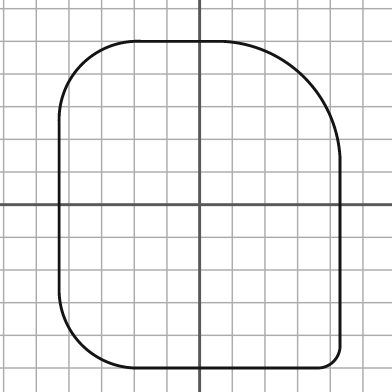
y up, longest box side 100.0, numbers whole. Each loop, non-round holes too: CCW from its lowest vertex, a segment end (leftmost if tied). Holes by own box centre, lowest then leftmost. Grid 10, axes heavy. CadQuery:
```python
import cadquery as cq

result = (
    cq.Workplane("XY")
    .moveTo(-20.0, -50.0)
    .lineTo(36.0, -50.0)
    .threePointArc((41.0, -48.0), (43.0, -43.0))
    .lineTo(43.0, 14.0)
    .threePointArc((32.0, 39.0), (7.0, 50.0))
    .lineTo(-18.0, 50.0)
    .threePointArc((-36.0, 43.0), (-43.0, 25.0))
    .lineTo(-43.0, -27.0)
    .threePointArc((-36.0, -43.0), (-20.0, -50.0))
    .close()
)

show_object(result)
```